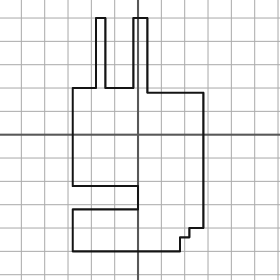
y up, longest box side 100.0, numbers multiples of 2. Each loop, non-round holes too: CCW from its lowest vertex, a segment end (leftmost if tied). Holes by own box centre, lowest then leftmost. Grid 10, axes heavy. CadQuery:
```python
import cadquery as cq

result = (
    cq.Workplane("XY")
    .moveTo(-28.0, -50.0)
    .lineTo(18.0, -50.0)
    .lineTo(18.0, -44.0)
    .lineTo(22.0, -44.0)
    .lineTo(22.0, -40.0)
    .lineTo(28.0, -40.0)
    .lineTo(28.0, 18.0)
    .lineTo(4.0, 18.0)
    .lineTo(4.0, 50.0)
    .lineTo(-2.0, 50.0)
    .lineTo(-2.0, 20.0)
    .lineTo(-14.0, 20.0)
    .lineTo(-14.0, 50.0)
    .lineTo(-18.0, 50.0)
    .lineTo(-18.0, 20.0)
    .lineTo(-28.0, 20.0)
    .lineTo(-28.0, -22.0)
    .lineTo(0.0, -22.0)
    .lineTo(0.0, -32.0)
    .lineTo(-28.0, -32.0)
    .close()
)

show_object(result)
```